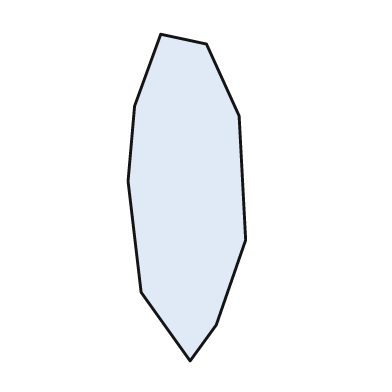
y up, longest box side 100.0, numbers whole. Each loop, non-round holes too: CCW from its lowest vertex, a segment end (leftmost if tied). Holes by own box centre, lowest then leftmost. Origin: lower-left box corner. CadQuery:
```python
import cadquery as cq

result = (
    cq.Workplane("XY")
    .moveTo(19.0, 0.0)
    .lineTo(27.0, 11.0)
    .lineTo(36.0, 37.0)
    .lineTo(34.0, 75.0)
    .lineTo(24.0, 97.0)
    .lineTo(10.0, 100.0)
    .lineTo(2.0, 78.0)
    .lineTo(0.0, 55.0)
    .lineTo(4.0, 21.0)
    .close()
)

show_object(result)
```